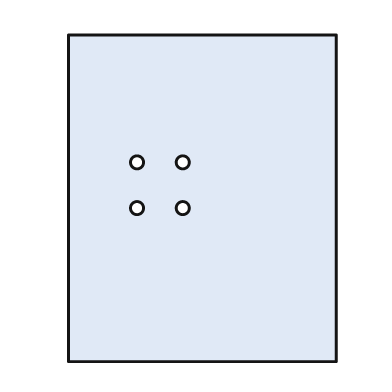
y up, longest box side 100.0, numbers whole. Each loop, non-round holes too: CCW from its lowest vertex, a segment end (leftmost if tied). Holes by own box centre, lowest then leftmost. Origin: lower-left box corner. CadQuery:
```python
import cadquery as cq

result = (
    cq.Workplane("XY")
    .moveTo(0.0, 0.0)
    .lineTo(82.0, 0.0)
    .lineTo(82.0, 100.0)
    .lineTo(0.0, 100.0)
    .close()
    .moveTo(21.0, 47.0)
    .circle(2.0)
    .moveTo(35.0, 47.0)
    .circle(2.0)
    .moveTo(21.0, 61.0)
    .circle(2.0)
    .moveTo(35.0, 61.0)
    .circle(2.0)
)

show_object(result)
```